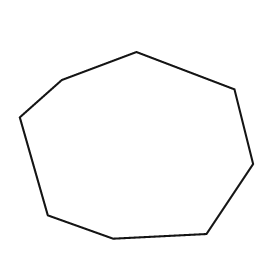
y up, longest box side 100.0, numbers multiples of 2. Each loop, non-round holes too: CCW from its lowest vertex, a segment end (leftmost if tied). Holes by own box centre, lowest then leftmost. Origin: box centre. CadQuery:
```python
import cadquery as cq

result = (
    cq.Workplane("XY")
    .moveTo(-10.0, -40.0)
    .lineTo(30.0, -38.0)
    .lineTo(50.0, -8.0)
    .lineTo(42.0, 24.0)
    .lineTo(0.0, 40.0)
    .lineTo(-32.0, 28.0)
    .lineTo(-50.0, 12.0)
    .lineTo(-38.0, -30.0)
    .close()
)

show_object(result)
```